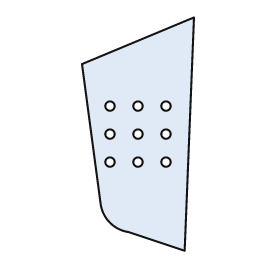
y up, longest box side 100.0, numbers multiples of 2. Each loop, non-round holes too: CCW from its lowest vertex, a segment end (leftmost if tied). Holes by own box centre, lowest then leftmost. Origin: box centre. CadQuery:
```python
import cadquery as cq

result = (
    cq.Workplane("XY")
    .moveTo(20.0, -50.0)
    .lineTo(24.0, 50.0)
    .lineTo(-24.0, 30.0)
    .lineTo(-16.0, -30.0)
    .threePointArc((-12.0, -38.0), (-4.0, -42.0))
    .close()
    .moveTo(-12.0, -12.0)
    .circle(2.0)
    .moveTo(0.0, -12.0)
    .circle(2.0)
    .moveTo(12.0, -12.0)
    .circle(2.0)
    .moveTo(-12.0, 0.0)
    .circle(2.0)
    .moveTo(0.0, 0.0)
    .circle(2.0)
    .moveTo(12.0, 0.0)
    .circle(2.0)
    .moveTo(-12.0, 12.0)
    .circle(2.0)
    .moveTo(0.0, 12.0)
    .circle(2.0)
    .moveTo(12.0, 12.0)
    .circle(2.0)
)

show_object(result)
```